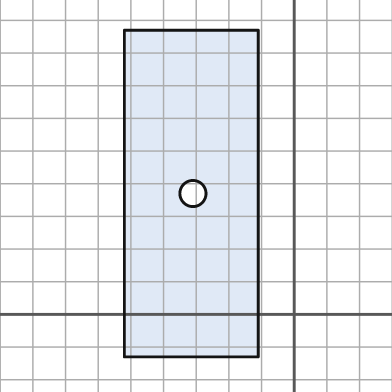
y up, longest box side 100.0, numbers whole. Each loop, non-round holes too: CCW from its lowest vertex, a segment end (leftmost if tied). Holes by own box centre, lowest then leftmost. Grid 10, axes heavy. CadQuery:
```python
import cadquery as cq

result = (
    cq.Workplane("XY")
    .moveTo(-52.0, -13.0)
    .lineTo(-11.0, -13.0)
    .lineTo(-11.0, 87.0)
    .lineTo(-52.0, 87.0)
    .close()
    .moveTo(-31.0, 37.0)
    .circle(4.0)
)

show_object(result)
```